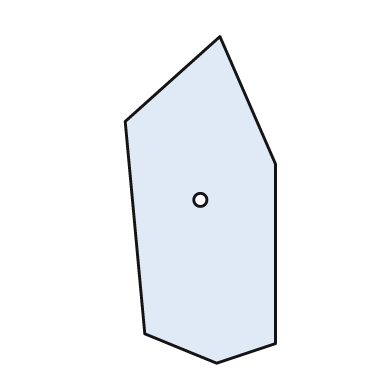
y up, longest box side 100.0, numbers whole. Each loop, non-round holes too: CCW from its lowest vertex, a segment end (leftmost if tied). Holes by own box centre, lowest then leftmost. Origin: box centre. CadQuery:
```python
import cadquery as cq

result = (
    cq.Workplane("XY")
    .moveTo(5.0, -50.0)
    .lineTo(23.0, -44.0)
    .lineTo(23.0, 11.0)
    .lineTo(6.0, 50.0)
    .lineTo(-23.0, 24.0)
    .lineTo(-17.0, -41.0)
    .close()
    .moveTo(0.0, 0.0)
    .circle(2.0)
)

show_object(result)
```